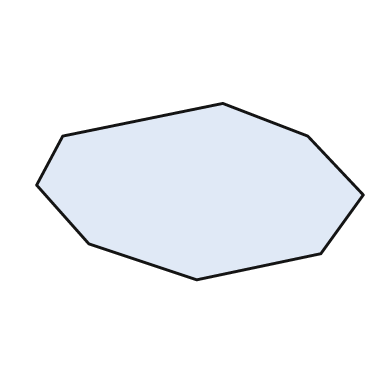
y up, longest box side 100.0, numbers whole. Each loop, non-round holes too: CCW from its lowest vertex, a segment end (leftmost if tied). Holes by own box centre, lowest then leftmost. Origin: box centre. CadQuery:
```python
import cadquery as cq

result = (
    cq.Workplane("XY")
    .moveTo(-1.0, -27.0)
    .lineTo(37.0, -19.0)
    .lineTo(50.0, -1.0)
    .lineTo(33.0, 17.0)
    .lineTo(7.0, 27.0)
    .lineTo(-42.0, 17.0)
    .lineTo(-50.0, 2.0)
    .lineTo(-34.0, -16.0)
    .close()
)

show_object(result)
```